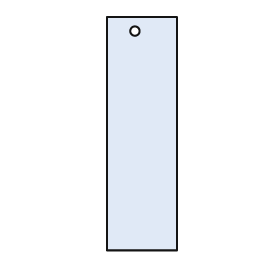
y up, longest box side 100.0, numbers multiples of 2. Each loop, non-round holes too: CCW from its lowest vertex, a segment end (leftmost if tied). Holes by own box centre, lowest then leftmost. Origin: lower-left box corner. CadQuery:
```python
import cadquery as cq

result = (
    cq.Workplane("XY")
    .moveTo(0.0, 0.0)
    .lineTo(30.0, 0.0)
    .lineTo(30.0, 100.0)
    .lineTo(0.0, 100.0)
    .close()
    .moveTo(12.0, 94.0)
    .circle(2.0)
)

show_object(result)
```